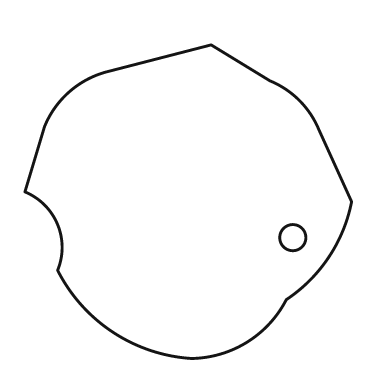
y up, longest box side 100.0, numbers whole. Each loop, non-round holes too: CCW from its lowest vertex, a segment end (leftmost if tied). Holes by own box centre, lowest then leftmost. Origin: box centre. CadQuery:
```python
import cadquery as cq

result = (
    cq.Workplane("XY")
    .moveTo(1.0, -48.0)
    .threePointArc((18.0, -43.0), (30.0, -30.0))
    .threePointArc((43.0, -17.0), (50.0, 0.0))
    .lineTo(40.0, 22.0)
    .threePointArc((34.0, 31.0), (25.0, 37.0))
    .lineTo(7.0, 48.0)
    .lineTo(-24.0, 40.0)
    .threePointArc((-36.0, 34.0), (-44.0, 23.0))
    .lineTo(-50.0, 3.0)
    .threePointArc((-40.0, -7.0), (-40.0, -21.0))
    .threePointArc((-23.0, -40.0), (1.0, -48.0))
    .close()
    .moveTo(32.0, -11.0)
    .circle(4.0)
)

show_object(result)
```